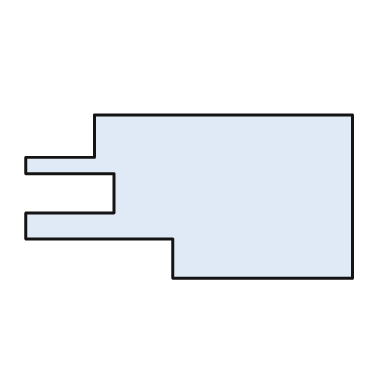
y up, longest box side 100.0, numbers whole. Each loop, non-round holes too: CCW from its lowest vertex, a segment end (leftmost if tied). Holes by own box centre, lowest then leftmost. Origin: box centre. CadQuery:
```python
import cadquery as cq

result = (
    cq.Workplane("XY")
    .moveTo(-5.0, -25.0)
    .lineTo(50.0, -25.0)
    .lineTo(50.0, 25.0)
    .lineTo(-29.0, 25.0)
    .lineTo(-29.0, 12.0)
    .lineTo(-50.0, 12.0)
    .lineTo(-50.0, 7.0)
    .lineTo(-23.0, 7.0)
    .lineTo(-23.0, -5.0)
    .lineTo(-50.0, -5.0)
    .lineTo(-50.0, -13.0)
    .lineTo(-5.0, -13.0)
    .close()
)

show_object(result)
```